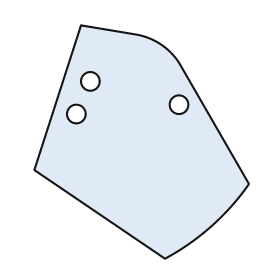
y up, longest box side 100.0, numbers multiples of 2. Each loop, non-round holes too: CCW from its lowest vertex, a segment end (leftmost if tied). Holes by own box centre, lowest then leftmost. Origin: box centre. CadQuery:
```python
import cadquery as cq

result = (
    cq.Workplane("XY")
    .moveTo(10.0, -50.0)
    .threePointArc((30.0, -36.0), (46.0, -18.0))
    .lineTo(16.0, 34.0)
    .threePointArc((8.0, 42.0), (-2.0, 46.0))
    .lineTo(-26.0, 50.0)
    .lineTo(-46.0, -12.0)
    .close()
    .moveTo(-28.0, 12.0)
    .circle(4.0)
    .moveTo(16.0, 16.0)
    .circle(4.0)
    .moveTo(-22.0, 26.0)
    .circle(4.0)
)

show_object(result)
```